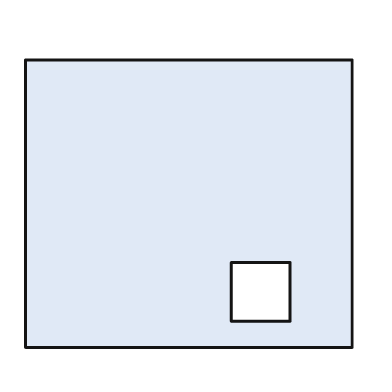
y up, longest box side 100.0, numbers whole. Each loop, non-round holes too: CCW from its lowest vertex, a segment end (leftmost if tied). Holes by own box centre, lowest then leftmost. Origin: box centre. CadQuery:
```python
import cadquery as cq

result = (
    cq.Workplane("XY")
    .moveTo(-50.0, -44.0)
    .lineTo(50.0, -44.0)
    .lineTo(50.0, 44.0)
    .lineTo(-50.0, 44.0)
    .close()
    .moveTo(13.0, -36.0)
    .lineTo(31.0, -36.0)
    .lineTo(31.0, -18.0)
    .lineTo(13.0, -18.0)
    .close()
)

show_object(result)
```